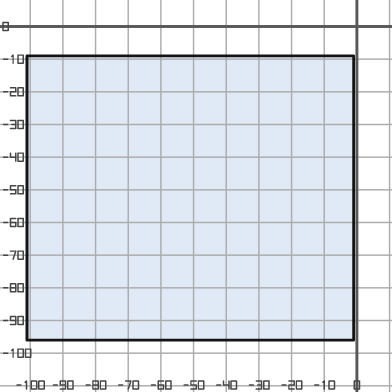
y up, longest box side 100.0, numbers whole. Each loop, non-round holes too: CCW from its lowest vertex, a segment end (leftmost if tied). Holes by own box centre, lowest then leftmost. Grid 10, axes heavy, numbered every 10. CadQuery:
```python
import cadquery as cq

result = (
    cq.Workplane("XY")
    .moveTo(-101.0, -96.0)
    .lineTo(-1.0, -96.0)
    .lineTo(-1.0, -9.0)
    .lineTo(-101.0, -9.0)
    .close()
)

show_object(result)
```